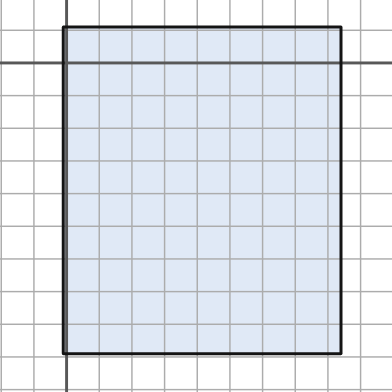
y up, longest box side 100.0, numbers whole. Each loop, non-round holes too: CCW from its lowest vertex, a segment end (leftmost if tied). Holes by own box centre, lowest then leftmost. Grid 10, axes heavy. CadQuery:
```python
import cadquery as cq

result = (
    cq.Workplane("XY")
    .moveTo(-1.0, -89.0)
    .lineTo(84.0, -89.0)
    .lineTo(84.0, 11.0)
    .lineTo(-1.0, 11.0)
    .close()
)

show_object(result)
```